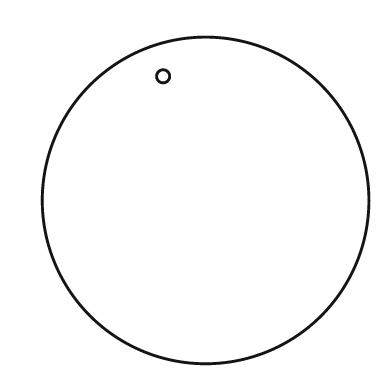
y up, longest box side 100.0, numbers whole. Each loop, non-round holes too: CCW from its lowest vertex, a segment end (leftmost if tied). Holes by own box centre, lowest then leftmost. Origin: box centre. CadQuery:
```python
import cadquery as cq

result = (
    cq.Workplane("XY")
    .moveTo(0.0, 0.0)
    .circle(50.0)
    .moveTo(-13.0, 38.0)
    .circle(2.0)
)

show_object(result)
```